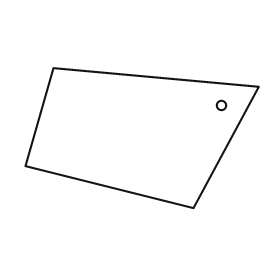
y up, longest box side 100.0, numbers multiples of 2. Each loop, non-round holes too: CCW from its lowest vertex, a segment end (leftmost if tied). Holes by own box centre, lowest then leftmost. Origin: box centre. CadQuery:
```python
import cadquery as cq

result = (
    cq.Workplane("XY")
    .moveTo(22.0, -30.0)
    .lineTo(50.0, 22.0)
    .lineTo(-38.0, 30.0)
    .lineTo(-50.0, -12.0)
    .close()
    .moveTo(34.0, 14.0)
    .circle(2.0)
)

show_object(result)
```